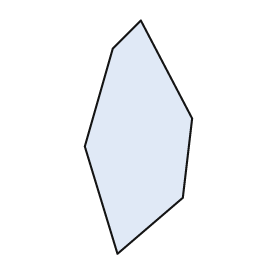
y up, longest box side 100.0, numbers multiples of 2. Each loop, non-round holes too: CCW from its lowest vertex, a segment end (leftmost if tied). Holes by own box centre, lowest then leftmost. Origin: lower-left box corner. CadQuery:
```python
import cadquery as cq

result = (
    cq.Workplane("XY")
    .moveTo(14.0, 0.0)
    .lineTo(42.0, 24.0)
    .lineTo(46.0, 58.0)
    .lineTo(24.0, 100.0)
    .lineTo(12.0, 88.0)
    .lineTo(0.0, 46.0)
    .close()
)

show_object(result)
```